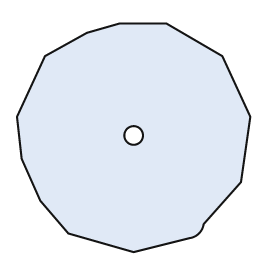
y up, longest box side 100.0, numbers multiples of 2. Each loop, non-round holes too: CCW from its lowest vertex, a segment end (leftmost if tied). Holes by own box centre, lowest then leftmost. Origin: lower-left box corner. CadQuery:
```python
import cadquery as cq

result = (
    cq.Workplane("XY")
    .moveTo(50.0, 0.0)
    .lineTo(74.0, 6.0)
    .threePointArc((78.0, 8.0), (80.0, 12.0))
    .lineTo(96.0, 30.0)
    .lineTo(100.0, 58.0)
    .lineTo(88.0, 84.0)
    .lineTo(64.0, 98.0)
    .lineTo(44.0, 98.0)
    .lineTo(30.0, 94.0)
    .lineTo(12.0, 84.0)
    .lineTo(0.0, 58.0)
    .lineTo(2.0, 40.0)
    .lineTo(10.0, 22.0)
    .lineTo(22.0, 8.0)
    .close()
    .moveTo(50.0, 50.0)
    .circle(4.0)
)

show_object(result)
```